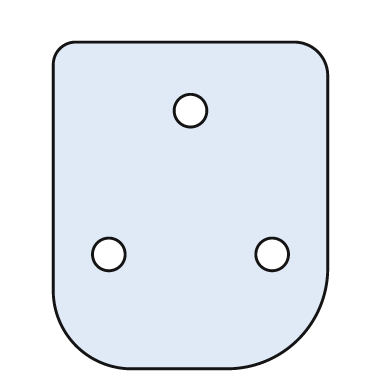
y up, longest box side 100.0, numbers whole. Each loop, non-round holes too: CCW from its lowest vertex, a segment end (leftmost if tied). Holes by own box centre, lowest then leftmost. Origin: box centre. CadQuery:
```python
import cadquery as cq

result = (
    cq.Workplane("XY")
    .moveTo(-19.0, -50.0)
    .lineTo(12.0, -50.0)
    .threePointArc((33.0, -41.0), (42.0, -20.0))
    .lineTo(42.0, 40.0)
    .threePointArc((39.0, 47.0), (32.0, 50.0))
    .lineTo(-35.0, 50.0)
    .threePointArc((-40.0, 48.0), (-42.0, 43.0))
    .lineTo(-42.0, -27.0)
    .threePointArc((-35.0, -43.0), (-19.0, -50.0))
    .close()
    .moveTo(-25.0, -15.0)
    .circle(5.0)
    .moveTo(25.0, -15.0)
    .circle(5.0)
    .moveTo(0.0, 29.0)
    .circle(5.0)
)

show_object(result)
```